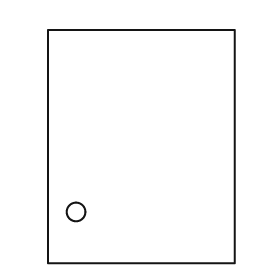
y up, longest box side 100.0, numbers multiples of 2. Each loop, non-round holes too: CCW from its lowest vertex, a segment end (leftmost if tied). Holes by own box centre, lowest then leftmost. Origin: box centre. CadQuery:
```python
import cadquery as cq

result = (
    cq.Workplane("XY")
    .moveTo(-40.0, -50.0)
    .lineTo(40.0, -50.0)
    .lineTo(40.0, 50.0)
    .lineTo(-40.0, 50.0)
    .close()
    .moveTo(-28.0, -28.0)
    .circle(4.0)
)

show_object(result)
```